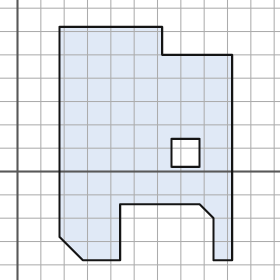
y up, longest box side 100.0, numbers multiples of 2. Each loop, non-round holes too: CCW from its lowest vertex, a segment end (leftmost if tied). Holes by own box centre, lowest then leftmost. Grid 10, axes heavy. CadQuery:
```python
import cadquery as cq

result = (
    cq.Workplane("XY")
    .moveTo(28.0, -38.0)
    .lineTo(44.0, -38.0)
    .lineTo(44.0, -14.0)
    .lineTo(78.0, -14.0)
    .lineTo(84.0, -20.0)
    .lineTo(84.0, -38.0)
    .lineTo(92.0, -38.0)
    .lineTo(92.0, 50.0)
    .lineTo(62.0, 50.0)
    .lineTo(62.0, 62.0)
    .lineTo(18.0, 62.0)
    .lineTo(18.0, -28.0)
    .close()
    .moveTo(66.0, 2.0)
    .lineTo(78.0, 2.0)
    .lineTo(78.0, 14.0)
    .lineTo(66.0, 14.0)
    .close()
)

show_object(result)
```